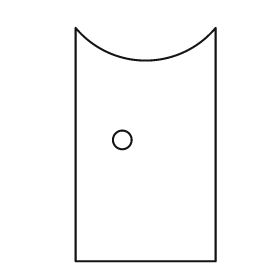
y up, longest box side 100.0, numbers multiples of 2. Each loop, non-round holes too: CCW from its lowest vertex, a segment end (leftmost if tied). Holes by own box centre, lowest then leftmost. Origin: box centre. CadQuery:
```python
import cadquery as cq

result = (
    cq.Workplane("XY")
    .moveTo(-30.0, -50.0)
    .lineTo(30.0, -50.0)
    .lineTo(30.0, 50.0)
    .threePointArc((0.0, 36.0), (-30.0, 50.0))
    .close()
    .moveTo(-10.0, 2.0)
    .circle(4.0)
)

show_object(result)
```